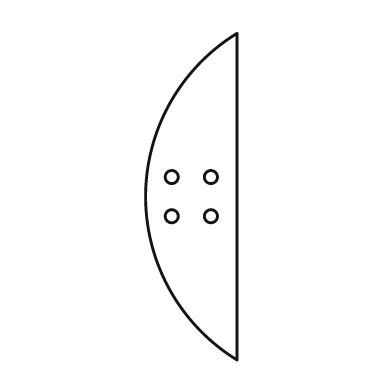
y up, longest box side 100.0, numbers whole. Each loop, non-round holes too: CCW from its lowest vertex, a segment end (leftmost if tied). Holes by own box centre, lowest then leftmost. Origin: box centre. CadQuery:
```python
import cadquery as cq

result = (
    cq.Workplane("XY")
    .moveTo(14.0, -50.0)
    .lineTo(14.0, 50.0)
    .threePointArc((-14.0, 0.0), (14.0, -50.0))
    .close()
    .moveTo(-6.0, -6.0)
    .circle(2.0)
    .moveTo(6.0, -6.0)
    .circle(2.0)
    .moveTo(-6.0, 6.0)
    .circle(2.0)
    .moveTo(6.0, 6.0)
    .circle(2.0)
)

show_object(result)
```